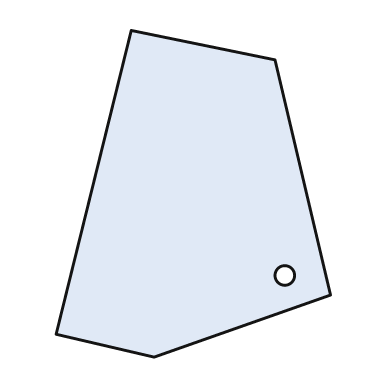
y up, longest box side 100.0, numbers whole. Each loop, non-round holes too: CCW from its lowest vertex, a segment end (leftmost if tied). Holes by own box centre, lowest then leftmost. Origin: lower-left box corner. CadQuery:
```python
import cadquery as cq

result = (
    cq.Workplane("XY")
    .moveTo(30.0, 0.0)
    .lineTo(84.0, 19.0)
    .lineTo(67.0, 91.0)
    .lineTo(23.0, 100.0)
    .lineTo(0.0, 7.0)
    .close()
    .moveTo(70.0, 25.0)
    .circle(3.0)
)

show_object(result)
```